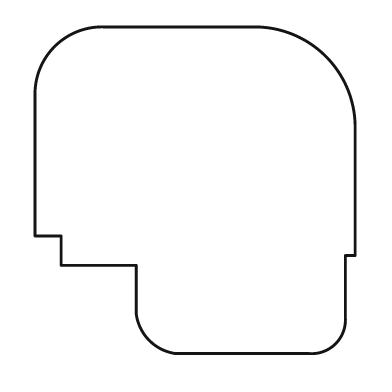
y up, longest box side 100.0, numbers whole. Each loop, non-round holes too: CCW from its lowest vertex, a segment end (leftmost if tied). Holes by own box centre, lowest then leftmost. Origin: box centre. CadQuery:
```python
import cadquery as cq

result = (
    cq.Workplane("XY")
    .moveTo(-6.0, -50.0)
    .lineTo(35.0, -50.0)
    .threePointArc((43.0, -47.0), (46.0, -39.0))
    .lineTo(46.0, -20.0)
    .lineTo(49.0, -20.0)
    .lineTo(49.0, 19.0)
    .threePointArc((40.0, 41.0), (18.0, 50.0))
    .lineTo(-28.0, 50.0)
    .threePointArc((-43.0, 44.0), (-49.0, 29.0))
    .lineTo(-49.0, -14.0)
    .lineTo(-41.0, -14.0)
    .lineTo(-41.0, -23.0)
    .lineTo(-18.0, -23.0)
    .lineTo(-18.0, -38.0)
    .threePointArc((-14.0, -46.0), (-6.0, -50.0))
    .close()
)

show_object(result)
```